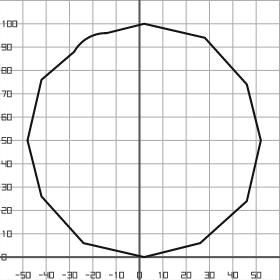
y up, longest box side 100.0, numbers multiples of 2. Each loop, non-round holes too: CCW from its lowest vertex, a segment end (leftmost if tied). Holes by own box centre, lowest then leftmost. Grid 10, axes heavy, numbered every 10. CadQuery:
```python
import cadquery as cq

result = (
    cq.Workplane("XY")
    .moveTo(2.0, 0.0)
    .lineTo(26.0, 6.0)
    .lineTo(46.0, 24.0)
    .lineTo(52.0, 50.0)
    .lineTo(46.0, 74.0)
    .lineTo(28.0, 94.0)
    .lineTo(2.0, 100.0)
    .lineTo(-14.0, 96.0)
    .threePointArc((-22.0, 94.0), (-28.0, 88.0))
    .lineTo(-42.0, 76.0)
    .lineTo(-48.0, 50.0)
    .lineTo(-42.0, 26.0)
    .lineTo(-24.0, 6.0)
    .close()
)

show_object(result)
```